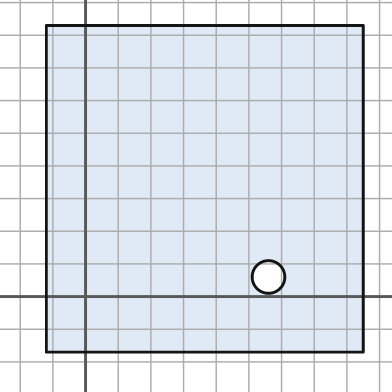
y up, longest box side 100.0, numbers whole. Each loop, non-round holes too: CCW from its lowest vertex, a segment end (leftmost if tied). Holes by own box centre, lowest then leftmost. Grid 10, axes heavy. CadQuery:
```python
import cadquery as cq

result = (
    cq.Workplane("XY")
    .moveTo(-12.0, -17.0)
    .lineTo(85.0, -17.0)
    .lineTo(85.0, 83.0)
    .lineTo(-12.0, 83.0)
    .close()
    .moveTo(56.0, 6.0)
    .circle(5.0)
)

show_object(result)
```